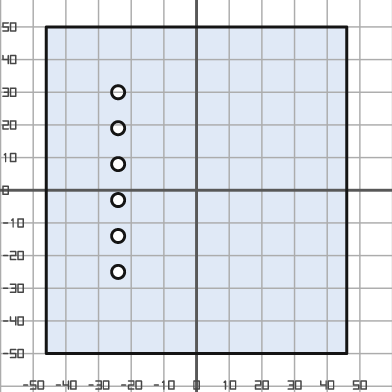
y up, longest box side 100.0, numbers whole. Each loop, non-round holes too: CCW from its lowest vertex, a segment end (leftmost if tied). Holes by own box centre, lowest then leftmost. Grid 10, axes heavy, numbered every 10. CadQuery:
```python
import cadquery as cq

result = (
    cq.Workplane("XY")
    .moveTo(-46.0, -50.0)
    .lineTo(46.0, -50.0)
    .lineTo(46.0, 50.0)
    .lineTo(-46.0, 50.0)
    .close()
    .moveTo(-24.0, -25.0)
    .circle(2.0)
    .moveTo(-24.0, -14.0)
    .circle(2.0)
    .moveTo(-24.0, -3.0)
    .circle(2.0)
    .moveTo(-24.0, 8.0)
    .circle(2.0)
    .moveTo(-24.0, 19.0)
    .circle(2.0)
    .moveTo(-24.0, 30.0)
    .circle(2.0)
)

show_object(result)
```